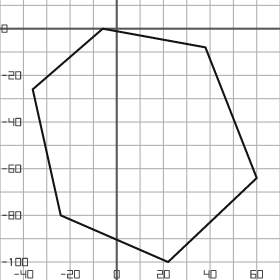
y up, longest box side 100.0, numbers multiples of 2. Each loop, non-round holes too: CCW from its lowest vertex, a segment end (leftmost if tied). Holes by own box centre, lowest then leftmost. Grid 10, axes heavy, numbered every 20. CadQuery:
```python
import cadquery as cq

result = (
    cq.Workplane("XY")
    .moveTo(22.0, -100.0)
    .lineTo(60.0, -64.0)
    .lineTo(38.0, -8.0)
    .lineTo(-6.0, 0.0)
    .lineTo(-36.0, -26.0)
    .lineTo(-24.0, -80.0)
    .close()
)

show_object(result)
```